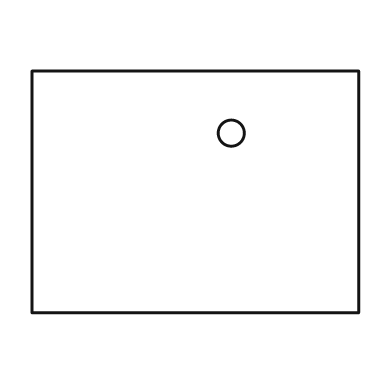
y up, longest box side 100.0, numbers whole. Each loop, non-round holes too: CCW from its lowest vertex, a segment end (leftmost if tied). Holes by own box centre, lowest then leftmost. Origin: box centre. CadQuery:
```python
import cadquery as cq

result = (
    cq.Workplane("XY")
    .moveTo(-50.0, -37.0)
    .lineTo(50.0, -37.0)
    .lineTo(50.0, 37.0)
    .lineTo(-50.0, 37.0)
    .close()
    .moveTo(11.0, 18.0)
    .circle(4.0)
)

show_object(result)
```